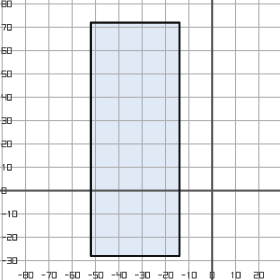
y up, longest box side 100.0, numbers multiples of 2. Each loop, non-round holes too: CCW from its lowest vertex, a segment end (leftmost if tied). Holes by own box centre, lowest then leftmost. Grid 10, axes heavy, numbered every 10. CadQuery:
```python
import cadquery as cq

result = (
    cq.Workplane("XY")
    .moveTo(-52.0, -28.0)
    .lineTo(-14.0, -28.0)
    .lineTo(-14.0, 72.0)
    .lineTo(-52.0, 72.0)
    .close()
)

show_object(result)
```